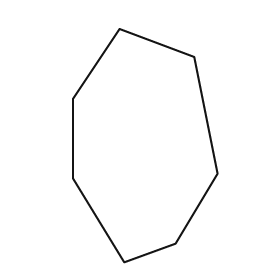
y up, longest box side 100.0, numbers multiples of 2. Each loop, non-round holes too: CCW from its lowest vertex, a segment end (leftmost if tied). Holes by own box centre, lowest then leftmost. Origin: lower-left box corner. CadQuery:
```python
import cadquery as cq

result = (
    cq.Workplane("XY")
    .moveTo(22.0, 0.0)
    .lineTo(44.0, 8.0)
    .lineTo(62.0, 38.0)
    .lineTo(52.0, 88.0)
    .lineTo(20.0, 100.0)
    .lineTo(0.0, 70.0)
    .lineTo(0.0, 36.0)
    .close()
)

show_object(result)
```